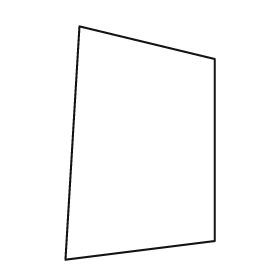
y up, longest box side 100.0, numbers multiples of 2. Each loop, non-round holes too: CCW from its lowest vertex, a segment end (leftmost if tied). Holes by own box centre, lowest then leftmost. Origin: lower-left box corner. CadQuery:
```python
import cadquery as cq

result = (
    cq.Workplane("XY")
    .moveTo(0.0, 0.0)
    .lineTo(64.0, 8.0)
    .lineTo(64.0, 86.0)
    .lineTo(6.0, 100.0)
    .close()
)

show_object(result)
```